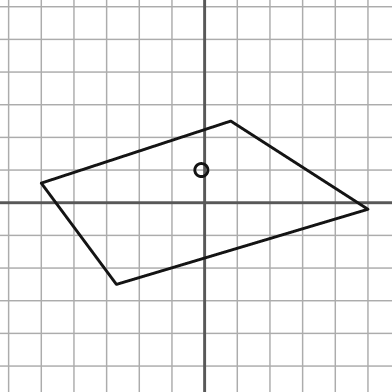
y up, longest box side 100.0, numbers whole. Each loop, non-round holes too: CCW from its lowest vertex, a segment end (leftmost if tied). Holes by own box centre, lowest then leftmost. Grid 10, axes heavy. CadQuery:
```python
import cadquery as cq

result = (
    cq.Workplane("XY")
    .moveTo(-27.0, -25.0)
    .lineTo(50.0, -2.0)
    .lineTo(8.0, 25.0)
    .lineTo(-50.0, 6.0)
    .close()
    .moveTo(-1.0, 10.0)
    .circle(2.0)
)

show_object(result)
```